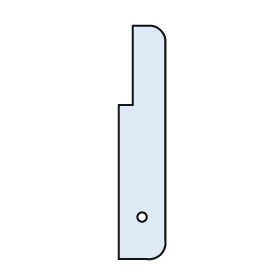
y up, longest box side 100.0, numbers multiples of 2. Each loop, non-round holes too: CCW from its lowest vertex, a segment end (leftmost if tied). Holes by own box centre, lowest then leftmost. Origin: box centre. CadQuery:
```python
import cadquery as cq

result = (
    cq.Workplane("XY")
    .moveTo(-10.0, -50.0)
    .lineTo(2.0, -50.0)
    .threePointArc((8.0, -48.0), (10.0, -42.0))
    .lineTo(10.0, 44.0)
    .threePointArc((8.0, 48.0), (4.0, 50.0))
    .lineTo(-4.0, 50.0)
    .lineTo(-4.0, 16.0)
    .lineTo(-10.0, 16.0)
    .close()
    .moveTo(0.0, -32.0)
    .circle(2.0)
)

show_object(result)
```